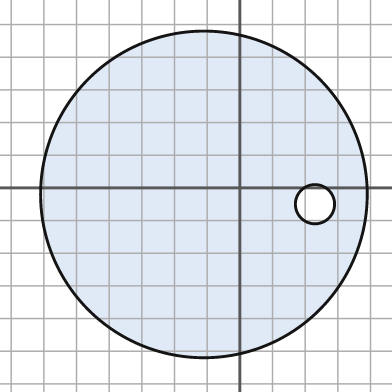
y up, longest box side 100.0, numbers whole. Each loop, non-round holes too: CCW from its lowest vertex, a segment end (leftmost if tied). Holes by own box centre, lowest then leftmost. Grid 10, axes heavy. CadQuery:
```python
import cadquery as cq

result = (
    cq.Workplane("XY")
    .moveTo(-11.0, -2.0)
    .circle(50.0)
    .moveTo(23.0, -5.0)
    .circle(6.0)
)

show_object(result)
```